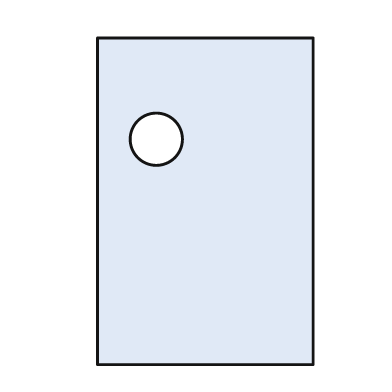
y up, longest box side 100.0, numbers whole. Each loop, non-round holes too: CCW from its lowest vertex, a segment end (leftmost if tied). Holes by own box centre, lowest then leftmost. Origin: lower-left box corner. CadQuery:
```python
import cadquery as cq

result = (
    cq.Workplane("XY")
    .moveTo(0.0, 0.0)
    .lineTo(66.0, 0.0)
    .lineTo(66.0, 100.0)
    .lineTo(0.0, 100.0)
    .close()
    .moveTo(18.0, 69.0)
    .circle(8.0)
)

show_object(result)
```